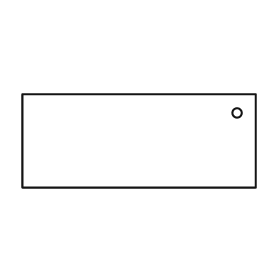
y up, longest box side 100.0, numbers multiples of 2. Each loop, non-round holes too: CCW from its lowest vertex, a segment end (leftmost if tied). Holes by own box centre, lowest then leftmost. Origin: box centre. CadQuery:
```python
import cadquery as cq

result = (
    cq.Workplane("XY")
    .moveTo(-50.0, -20.0)
    .lineTo(50.0, -20.0)
    .lineTo(50.0, 20.0)
    .lineTo(-50.0, 20.0)
    .close()
    .moveTo(42.0, 12.0)
    .circle(2.0)
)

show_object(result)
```